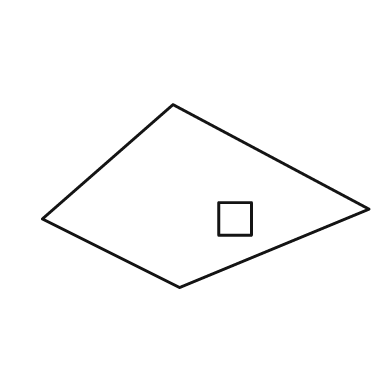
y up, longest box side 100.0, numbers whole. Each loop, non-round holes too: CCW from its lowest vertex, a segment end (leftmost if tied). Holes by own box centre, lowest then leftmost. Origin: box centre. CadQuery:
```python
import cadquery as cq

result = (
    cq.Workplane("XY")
    .moveTo(-8.0, -28.0)
    .lineTo(50.0, -4.0)
    .lineTo(-10.0, 28.0)
    .lineTo(-50.0, -7.0)
    .close()
    .moveTo(4.0, -12.0)
    .lineTo(14.0, -12.0)
    .lineTo(14.0, -2.0)
    .lineTo(4.0, -2.0)
    .close()
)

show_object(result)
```